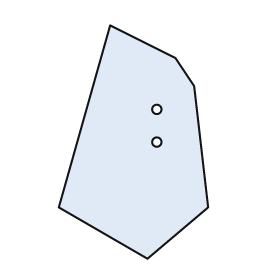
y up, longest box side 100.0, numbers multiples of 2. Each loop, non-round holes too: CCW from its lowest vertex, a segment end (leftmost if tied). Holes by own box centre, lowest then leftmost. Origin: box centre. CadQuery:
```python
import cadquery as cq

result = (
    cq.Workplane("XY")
    .moveTo(6.0, -50.0)
    .lineTo(32.0, -28.0)
    .lineTo(26.0, 24.0)
    .lineTo(18.0, 36.0)
    .lineTo(-10.0, 50.0)
    .lineTo(-32.0, -28.0)
    .close()
    .moveTo(10.0, 0.0)
    .circle(2.0)
    .moveTo(10.0, 14.0)
    .circle(2.0)
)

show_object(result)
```